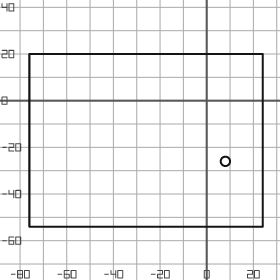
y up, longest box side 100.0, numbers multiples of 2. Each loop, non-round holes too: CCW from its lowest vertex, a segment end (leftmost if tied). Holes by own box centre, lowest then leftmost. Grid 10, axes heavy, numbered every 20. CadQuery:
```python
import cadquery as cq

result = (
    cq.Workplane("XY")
    .moveTo(-76.0, -54.0)
    .lineTo(24.0, -54.0)
    .lineTo(24.0, 20.0)
    .lineTo(-76.0, 20.0)
    .close()
    .moveTo(8.0, -26.0)
    .circle(2.0)
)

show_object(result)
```